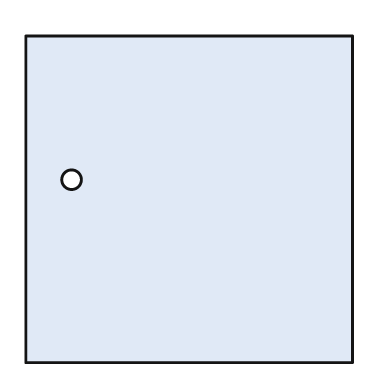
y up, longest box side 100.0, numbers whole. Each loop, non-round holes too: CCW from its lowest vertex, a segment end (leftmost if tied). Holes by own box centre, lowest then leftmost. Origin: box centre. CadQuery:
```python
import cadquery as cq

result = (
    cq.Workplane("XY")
    .moveTo(-50.0, -50.0)
    .lineTo(50.0, -50.0)
    .lineTo(50.0, 50.0)
    .lineTo(-50.0, 50.0)
    .close()
    .moveTo(-36.0, 6.0)
    .circle(3.0)
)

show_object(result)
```